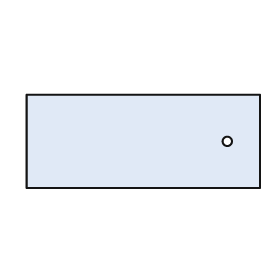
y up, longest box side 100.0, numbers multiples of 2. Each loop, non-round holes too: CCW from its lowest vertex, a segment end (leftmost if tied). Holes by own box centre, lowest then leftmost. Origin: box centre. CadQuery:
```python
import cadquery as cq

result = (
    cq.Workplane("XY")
    .moveTo(-50.0, -20.0)
    .lineTo(50.0, -20.0)
    .lineTo(50.0, 20.0)
    .lineTo(-50.0, 20.0)
    .close()
    .moveTo(36.0, 0.0)
    .circle(2.0)
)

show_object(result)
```